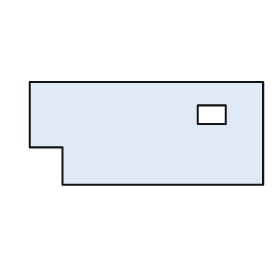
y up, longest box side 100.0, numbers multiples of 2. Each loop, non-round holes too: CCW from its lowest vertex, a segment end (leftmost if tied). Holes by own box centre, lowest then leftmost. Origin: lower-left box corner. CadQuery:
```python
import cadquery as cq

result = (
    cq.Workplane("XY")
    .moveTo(14.0, 0.0)
    .lineTo(100.0, 0.0)
    .lineTo(100.0, 44.0)
    .lineTo(0.0, 44.0)
    .lineTo(0.0, 16.0)
    .lineTo(14.0, 16.0)
    .close()
    .moveTo(72.0, 26.0)
    .lineTo(84.0, 26.0)
    .lineTo(84.0, 34.0)
    .lineTo(72.0, 34.0)
    .close()
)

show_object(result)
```